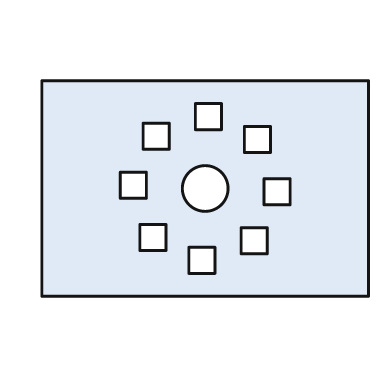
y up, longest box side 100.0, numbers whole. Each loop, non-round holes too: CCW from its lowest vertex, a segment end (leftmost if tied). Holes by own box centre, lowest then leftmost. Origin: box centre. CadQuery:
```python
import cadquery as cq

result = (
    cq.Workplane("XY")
    .moveTo(-50.0, -33.0)
    .lineTo(50.0, -33.0)
    .lineTo(50.0, 33.0)
    .lineTo(-50.0, 33.0)
    .close()
    .moveTo(-5.0, -26.0)
    .lineTo(3.0, -26.0)
    .lineTo(3.0, -18.0)
    .lineTo(-5.0, -18.0)
    .close()
    .moveTo(11.0, -20.0)
    .lineTo(19.0, -20.0)
    .lineTo(19.0, -12.0)
    .lineTo(11.0, -12.0)
    .close()
    .moveTo(-20.0, -19.0)
    .lineTo(-12.0, -19.0)
    .lineTo(-12.0, -11.0)
    .lineTo(-20.0, -11.0)
    .close()
    .moveTo(18.0, -5.0)
    .lineTo(26.0, -5.0)
    .lineTo(26.0, 3.0)
    .lineTo(18.0, 3.0)
    .close()
    .moveTo(0.0, 0.0)
    .circle(7.0)
    .moveTo(-26.0, -3.0)
    .lineTo(-18.0, -3.0)
    .lineTo(-18.0, 5.0)
    .lineTo(-26.0, 5.0)
    .close()
    .moveTo(12.0, 11.0)
    .lineTo(20.0, 11.0)
    .lineTo(20.0, 19.0)
    .lineTo(12.0, 19.0)
    .close()
    .moveTo(-19.0, 12.0)
    .lineTo(-11.0, 12.0)
    .lineTo(-11.0, 20.0)
    .lineTo(-19.0, 20.0)
    .close()
    .moveTo(-3.0, 18.0)
    .lineTo(5.0, 18.0)
    .lineTo(5.0, 26.0)
    .lineTo(-3.0, 26.0)
    .close()
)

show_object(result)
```